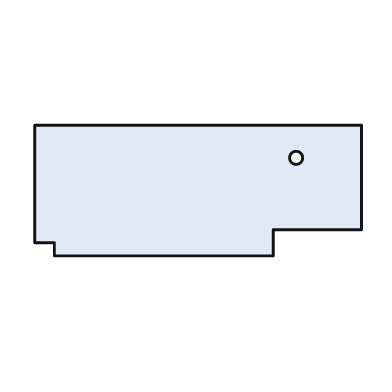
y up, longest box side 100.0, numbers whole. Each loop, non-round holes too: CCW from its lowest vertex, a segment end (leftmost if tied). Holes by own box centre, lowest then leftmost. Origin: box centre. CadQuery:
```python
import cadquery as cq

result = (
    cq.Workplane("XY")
    .moveTo(-44.0, -20.0)
    .lineTo(23.0, -20.0)
    .lineTo(23.0, -12.0)
    .lineTo(50.0, -12.0)
    .lineTo(50.0, 20.0)
    .lineTo(-50.0, 20.0)
    .lineTo(-50.0, -16.0)
    .lineTo(-44.0, -16.0)
    .close()
    .moveTo(30.0, 10.0)
    .circle(2.0)
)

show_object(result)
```